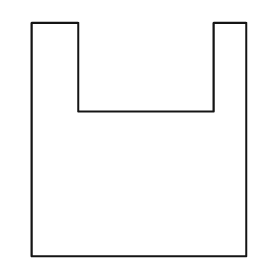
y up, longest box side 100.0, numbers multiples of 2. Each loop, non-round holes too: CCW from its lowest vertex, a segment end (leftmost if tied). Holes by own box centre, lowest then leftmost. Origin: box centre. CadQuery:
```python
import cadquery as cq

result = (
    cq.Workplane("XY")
    .moveTo(-46.0, -50.0)
    .lineTo(46.0, -50.0)
    .lineTo(46.0, 50.0)
    .lineTo(32.0, 50.0)
    .lineTo(32.0, 12.0)
    .lineTo(-26.0, 12.0)
    .lineTo(-26.0, 50.0)
    .lineTo(-46.0, 50.0)
    .close()
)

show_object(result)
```